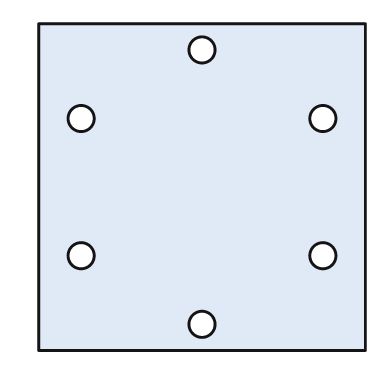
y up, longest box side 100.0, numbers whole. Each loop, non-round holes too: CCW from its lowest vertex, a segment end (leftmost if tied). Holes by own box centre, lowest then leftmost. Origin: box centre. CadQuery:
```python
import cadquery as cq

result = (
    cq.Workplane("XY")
    .moveTo(-50.0, -50.0)
    .lineTo(50.0, -50.0)
    .lineTo(50.0, 50.0)
    .lineTo(-50.0, 50.0)
    .close()
    .moveTo(0.0, -42.0)
    .circle(4.0)
    .moveTo(-37.0, -21.0)
    .circle(4.0)
    .moveTo(37.0, -21.0)
    .circle(4.0)
    .moveTo(-37.0, 21.0)
    .circle(4.0)
    .moveTo(37.0, 21.0)
    .circle(4.0)
    .moveTo(0.0, 42.0)
    .circle(4.0)
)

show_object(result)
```